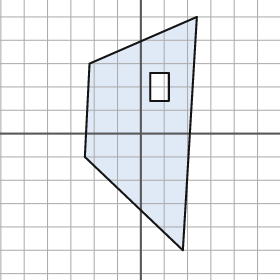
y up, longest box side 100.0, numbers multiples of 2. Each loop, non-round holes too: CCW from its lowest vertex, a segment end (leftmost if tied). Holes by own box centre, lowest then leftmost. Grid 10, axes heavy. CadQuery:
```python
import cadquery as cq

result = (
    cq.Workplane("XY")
    .moveTo(18.0, -50.0)
    .lineTo(24.0, 50.0)
    .lineTo(-22.0, 30.0)
    .lineTo(-24.0, -10.0)
    .close()
    .moveTo(4.0, 14.0)
    .lineTo(12.0, 14.0)
    .lineTo(12.0, 26.0)
    .lineTo(4.0, 26.0)
    .close()
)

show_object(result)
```